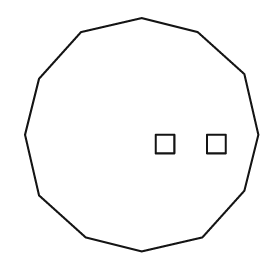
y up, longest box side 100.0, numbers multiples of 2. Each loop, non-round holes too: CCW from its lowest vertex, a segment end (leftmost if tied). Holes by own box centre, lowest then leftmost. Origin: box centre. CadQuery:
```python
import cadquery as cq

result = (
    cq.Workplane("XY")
    .moveTo(0.0, -50.0)
    .lineTo(26.0, -44.0)
    .lineTo(44.0, -24.0)
    .lineTo(50.0, 0.0)
    .lineTo(44.0, 26.0)
    .lineTo(24.0, 44.0)
    .lineTo(0.0, 50.0)
    .lineTo(-26.0, 44.0)
    .lineTo(-44.0, 24.0)
    .lineTo(-50.0, 0.0)
    .lineTo(-44.0, -26.0)
    .lineTo(-24.0, -44.0)
    .close()
    .moveTo(6.0, -8.0)
    .lineTo(14.0, -8.0)
    .lineTo(14.0, 0.0)
    .lineTo(6.0, 0.0)
    .close()
    .moveTo(28.0, -8.0)
    .lineTo(36.0, -8.0)
    .lineTo(36.0, 0.0)
    .lineTo(28.0, 0.0)
    .close()
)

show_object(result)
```